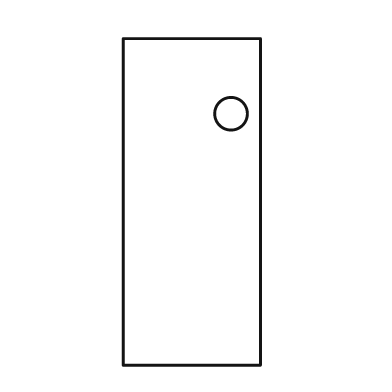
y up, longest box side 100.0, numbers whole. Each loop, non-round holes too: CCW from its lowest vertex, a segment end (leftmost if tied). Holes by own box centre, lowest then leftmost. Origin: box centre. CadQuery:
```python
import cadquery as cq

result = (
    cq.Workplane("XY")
    .moveTo(-21.0, -50.0)
    .lineTo(21.0, -50.0)
    .lineTo(21.0, 50.0)
    .lineTo(-21.0, 50.0)
    .close()
    .moveTo(12.0, 27.0)
    .circle(5.0)
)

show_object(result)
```